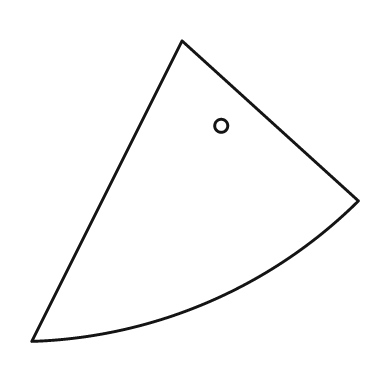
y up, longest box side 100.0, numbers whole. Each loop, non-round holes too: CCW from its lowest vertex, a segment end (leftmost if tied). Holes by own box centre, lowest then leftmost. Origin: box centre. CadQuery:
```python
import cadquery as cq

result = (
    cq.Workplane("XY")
    .moveTo(-50.0, -46.0)
    .threePointArc((4.0, -34.0), (50.0, -3.0))
    .lineTo(-4.0, 46.0)
    .close()
    .moveTo(8.0, 20.0)
    .circle(2.0)
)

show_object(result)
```